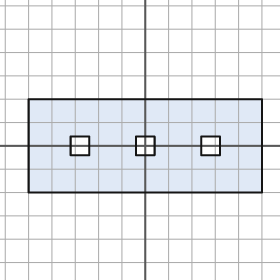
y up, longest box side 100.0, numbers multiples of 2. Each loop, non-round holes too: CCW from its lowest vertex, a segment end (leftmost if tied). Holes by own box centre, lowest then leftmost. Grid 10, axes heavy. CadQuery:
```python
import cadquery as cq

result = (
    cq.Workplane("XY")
    .moveTo(-50.0, -20.0)
    .lineTo(50.0, -20.0)
    .lineTo(50.0, 20.0)
    .lineTo(-50.0, 20.0)
    .close()
    .moveTo(-32.0, -4.0)
    .lineTo(-24.0, -4.0)
    .lineTo(-24.0, 4.0)
    .lineTo(-32.0, 4.0)
    .close()
    .moveTo(-4.0, -4.0)
    .lineTo(4.0, -4.0)
    .lineTo(4.0, 4.0)
    .lineTo(-4.0, 4.0)
    .close()
    .moveTo(24.0, -4.0)
    .lineTo(32.0, -4.0)
    .lineTo(32.0, 4.0)
    .lineTo(24.0, 4.0)
    .close()
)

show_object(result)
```